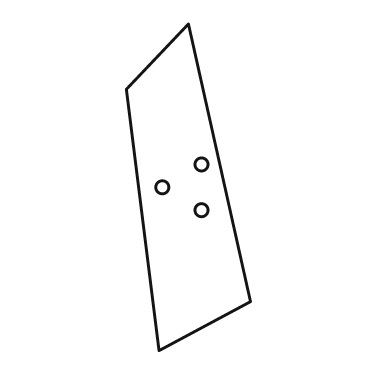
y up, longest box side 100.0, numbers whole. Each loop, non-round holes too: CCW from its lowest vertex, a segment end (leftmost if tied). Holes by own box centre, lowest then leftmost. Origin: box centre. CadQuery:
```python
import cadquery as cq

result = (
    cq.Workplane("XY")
    .moveTo(-9.0, -50.0)
    .lineTo(19.0, -35.0)
    .lineTo(0.0, 50.0)
    .lineTo(-19.0, 30.0)
    .close()
    .moveTo(4.0, -7.0)
    .circle(2.0)
    .moveTo(-8.0, 0.0)
    .circle(2.0)
    .moveTo(4.0, 7.0)
    .circle(2.0)
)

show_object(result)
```